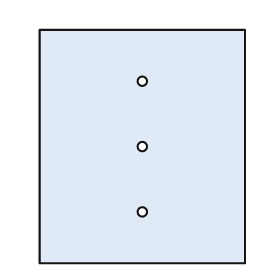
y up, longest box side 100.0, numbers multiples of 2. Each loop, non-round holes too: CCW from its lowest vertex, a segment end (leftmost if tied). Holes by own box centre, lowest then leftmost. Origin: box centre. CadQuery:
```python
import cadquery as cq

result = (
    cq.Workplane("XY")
    .moveTo(-44.0, -50.0)
    .lineTo(44.0, -50.0)
    .lineTo(44.0, 50.0)
    .lineTo(-44.0, 50.0)
    .close()
    .moveTo(0.0, -28.0)
    .circle(2.0)
    .moveTo(0.0, 0.0)
    .circle(2.0)
    .moveTo(0.0, 28.0)
    .circle(2.0)
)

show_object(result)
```